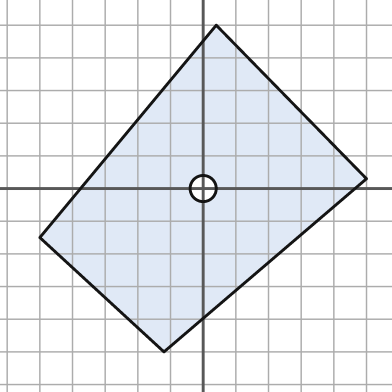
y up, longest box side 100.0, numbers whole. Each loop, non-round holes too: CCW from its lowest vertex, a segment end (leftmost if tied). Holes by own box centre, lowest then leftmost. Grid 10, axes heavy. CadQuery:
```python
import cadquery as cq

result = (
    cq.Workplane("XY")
    .moveTo(-12.0, -50.0)
    .lineTo(50.0, 3.0)
    .lineTo(4.0, 50.0)
    .lineTo(-50.0, -15.0)
    .close()
    .moveTo(0.0, 0.0)
    .circle(4.0)
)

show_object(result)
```